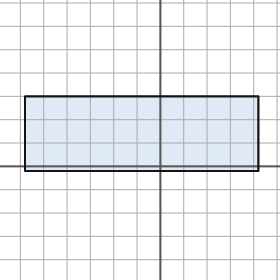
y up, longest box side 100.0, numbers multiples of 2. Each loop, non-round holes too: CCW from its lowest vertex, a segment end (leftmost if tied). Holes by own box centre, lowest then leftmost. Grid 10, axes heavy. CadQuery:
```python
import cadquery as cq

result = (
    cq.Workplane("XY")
    .moveTo(-58.0, -2.0)
    .lineTo(42.0, -2.0)
    .lineTo(42.0, 30.0)
    .lineTo(-58.0, 30.0)
    .close()
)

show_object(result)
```